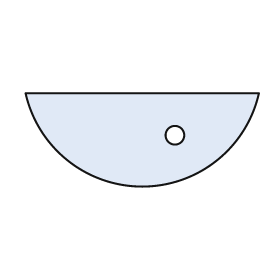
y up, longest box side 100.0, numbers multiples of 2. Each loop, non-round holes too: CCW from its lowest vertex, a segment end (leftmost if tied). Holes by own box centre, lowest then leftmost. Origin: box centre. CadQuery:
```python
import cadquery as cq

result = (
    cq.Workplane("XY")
    .moveTo(-50.0, 20.0)
    .threePointArc((0.0, -20.0), (50.0, 20.0))
    .close()
    .moveTo(14.0, 2.0)
    .circle(4.0)
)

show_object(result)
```